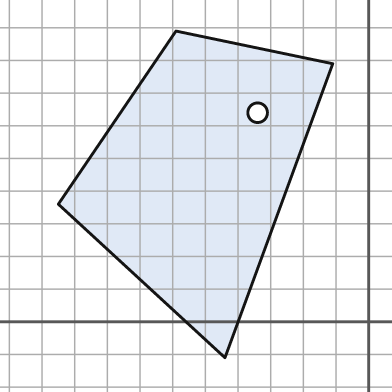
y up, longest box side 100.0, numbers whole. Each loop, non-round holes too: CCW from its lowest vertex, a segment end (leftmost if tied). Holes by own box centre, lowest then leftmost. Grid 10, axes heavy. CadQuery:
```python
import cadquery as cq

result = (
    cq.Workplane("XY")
    .moveTo(-44.0, -11.0)
    .lineTo(-11.0, 79.0)
    .lineTo(-59.0, 89.0)
    .lineTo(-95.0, 36.0)
    .close()
    .moveTo(-34.0, 64.0)
    .circle(3.0)
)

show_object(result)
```